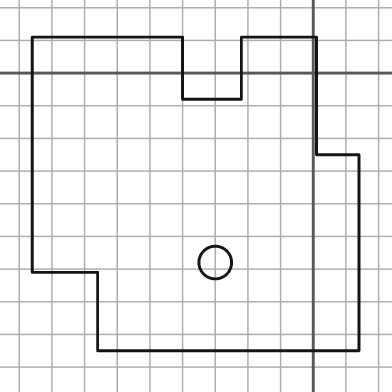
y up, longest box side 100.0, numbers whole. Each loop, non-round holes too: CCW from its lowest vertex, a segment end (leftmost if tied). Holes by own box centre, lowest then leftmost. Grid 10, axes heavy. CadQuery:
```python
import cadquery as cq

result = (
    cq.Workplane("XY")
    .moveTo(-66.0, -85.0)
    .lineTo(14.0, -85.0)
    .lineTo(14.0, -25.0)
    .lineTo(1.0, -25.0)
    .lineTo(1.0, 11.0)
    .lineTo(-22.0, 11.0)
    .lineTo(-22.0, -8.0)
    .lineTo(-40.0, -8.0)
    .lineTo(-40.0, 11.0)
    .lineTo(-86.0, 11.0)
    .lineTo(-86.0, -61.0)
    .lineTo(-66.0, -61.0)
    .close()
    .moveTo(-30.0, -58.0)
    .circle(5.0)
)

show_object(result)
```